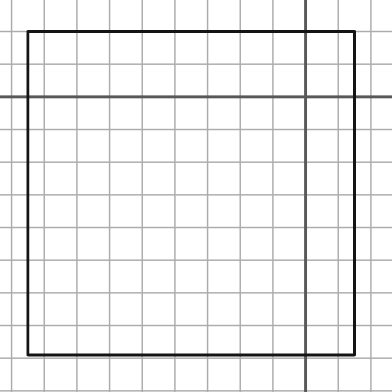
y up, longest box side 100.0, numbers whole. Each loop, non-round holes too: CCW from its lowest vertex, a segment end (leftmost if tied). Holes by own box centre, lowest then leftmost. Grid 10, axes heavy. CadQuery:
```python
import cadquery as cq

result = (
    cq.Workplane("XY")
    .moveTo(-85.0, -79.0)
    .lineTo(15.0, -79.0)
    .lineTo(15.0, 20.0)
    .lineTo(-85.0, 20.0)
    .close()
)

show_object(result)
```